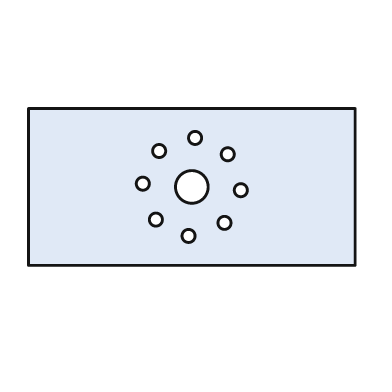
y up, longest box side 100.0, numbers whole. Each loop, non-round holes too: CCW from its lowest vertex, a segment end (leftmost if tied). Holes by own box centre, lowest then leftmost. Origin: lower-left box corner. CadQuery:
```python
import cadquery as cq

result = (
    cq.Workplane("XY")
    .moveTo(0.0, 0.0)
    .lineTo(100.0, 0.0)
    .lineTo(100.0, 48.0)
    .lineTo(0.0, 48.0)
    .close()
    .moveTo(49.0, 9.0)
    .circle(2.0)
    .moveTo(60.0, 13.0)
    .circle(2.0)
    .moveTo(39.0, 14.0)
    .circle(2.0)
    .moveTo(65.0, 23.0)
    .circle(2.0)
    .moveTo(50.0, 24.0)
    .circle(5.0)
    .moveTo(35.0, 25.0)
    .circle(2.0)
    .moveTo(61.0, 34.0)
    .circle(2.0)
    .moveTo(40.0, 35.0)
    .circle(2.0)
    .moveTo(51.0, 39.0)
    .circle(2.0)
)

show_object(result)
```